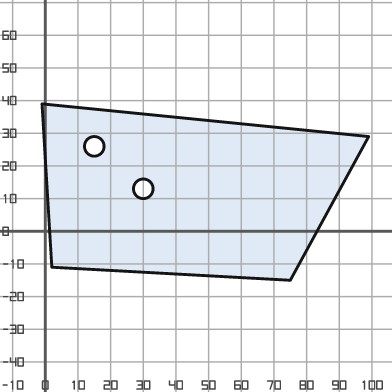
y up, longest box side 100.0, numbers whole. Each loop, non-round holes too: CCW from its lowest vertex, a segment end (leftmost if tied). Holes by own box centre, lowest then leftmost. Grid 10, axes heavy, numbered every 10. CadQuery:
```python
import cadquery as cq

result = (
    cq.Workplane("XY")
    .moveTo(75.0, -15.0)
    .lineTo(99.0, 29.0)
    .lineTo(-1.0, 39.0)
    .lineTo(2.0, -11.0)
    .close()
    .moveTo(30.0, 13.0)
    .circle(3.0)
    .moveTo(15.0, 26.0)
    .circle(3.0)
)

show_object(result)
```